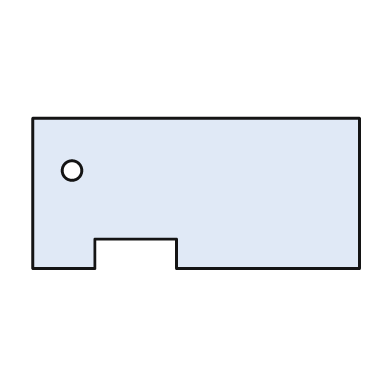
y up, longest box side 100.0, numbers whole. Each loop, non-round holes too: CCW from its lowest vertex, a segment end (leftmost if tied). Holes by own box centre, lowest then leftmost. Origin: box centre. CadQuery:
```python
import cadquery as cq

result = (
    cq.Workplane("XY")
    .moveTo(-50.0, -23.0)
    .lineTo(-31.0, -23.0)
    .lineTo(-31.0, -14.0)
    .lineTo(-6.0, -14.0)
    .lineTo(-6.0, -23.0)
    .lineTo(50.0, -23.0)
    .lineTo(50.0, 23.0)
    .lineTo(-50.0, 23.0)
    .close()
    .moveTo(-38.0, 7.0)
    .circle(3.0)
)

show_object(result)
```